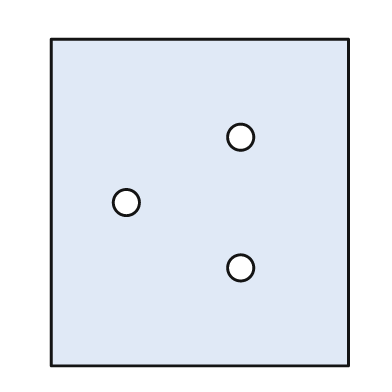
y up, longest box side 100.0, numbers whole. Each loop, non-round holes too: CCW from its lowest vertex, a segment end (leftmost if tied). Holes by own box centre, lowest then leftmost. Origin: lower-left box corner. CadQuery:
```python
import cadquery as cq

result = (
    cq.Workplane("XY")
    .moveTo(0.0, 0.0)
    .lineTo(91.0, 0.0)
    .lineTo(91.0, 100.0)
    .lineTo(0.0, 100.0)
    .close()
    .moveTo(58.0, 30.0)
    .circle(4.0)
    .moveTo(23.0, 50.0)
    .circle(4.0)
    .moveTo(58.0, 70.0)
    .circle(4.0)
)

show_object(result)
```